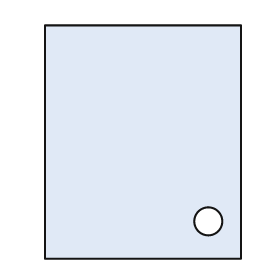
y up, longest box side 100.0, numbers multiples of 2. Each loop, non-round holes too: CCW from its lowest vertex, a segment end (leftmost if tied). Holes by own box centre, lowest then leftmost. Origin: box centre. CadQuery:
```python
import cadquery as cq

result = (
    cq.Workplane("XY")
    .moveTo(-42.0, -50.0)
    .lineTo(42.0, -50.0)
    .lineTo(42.0, 50.0)
    .lineTo(-42.0, 50.0)
    .close()
    .moveTo(28.0, -34.0)
    .circle(6.0)
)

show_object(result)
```